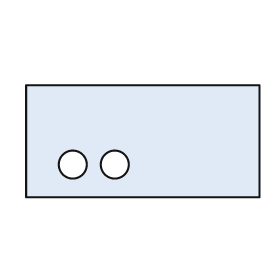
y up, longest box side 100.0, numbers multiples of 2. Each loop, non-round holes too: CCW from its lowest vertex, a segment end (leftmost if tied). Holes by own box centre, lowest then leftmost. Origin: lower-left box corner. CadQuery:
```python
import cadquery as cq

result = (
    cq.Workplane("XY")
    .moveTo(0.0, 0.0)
    .lineTo(100.0, 0.0)
    .lineTo(100.0, 48.0)
    .lineTo(0.0, 48.0)
    .close()
    .moveTo(20.0, 14.0)
    .circle(6.0)
    .moveTo(38.0, 14.0)
    .circle(6.0)
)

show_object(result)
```